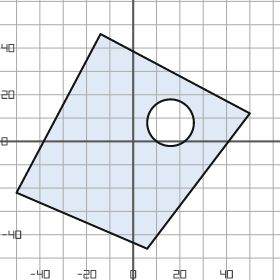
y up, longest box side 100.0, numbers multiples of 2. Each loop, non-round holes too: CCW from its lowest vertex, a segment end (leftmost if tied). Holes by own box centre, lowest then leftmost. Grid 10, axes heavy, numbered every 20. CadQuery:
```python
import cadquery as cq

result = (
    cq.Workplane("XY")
    .moveTo(6.0, -46.0)
    .lineTo(50.0, 12.0)
    .lineTo(-14.0, 46.0)
    .lineTo(-50.0, -22.0)
    .close()
    .moveTo(16.0, 8.0)
    .circle(10.0)
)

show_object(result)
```